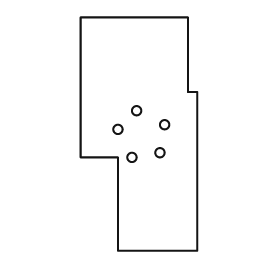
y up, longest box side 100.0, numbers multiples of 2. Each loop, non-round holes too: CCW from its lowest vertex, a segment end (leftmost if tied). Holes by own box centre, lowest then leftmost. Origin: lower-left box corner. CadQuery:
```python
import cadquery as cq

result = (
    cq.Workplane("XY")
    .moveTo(16.0, 0.0)
    .lineTo(50.0, 0.0)
    .lineTo(50.0, 68.0)
    .lineTo(46.0, 68.0)
    .lineTo(46.0, 100.0)
    .lineTo(0.0, 100.0)
    .lineTo(0.0, 40.0)
    .lineTo(16.0, 40.0)
    .close()
    .moveTo(22.0, 40.0)
    .circle(2.0)
    .moveTo(34.0, 42.0)
    .circle(2.0)
    .moveTo(16.0, 52.0)
    .circle(2.0)
    .moveTo(36.0, 54.0)
    .circle(2.0)
    .moveTo(24.0, 60.0)
    .circle(2.0)
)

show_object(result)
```